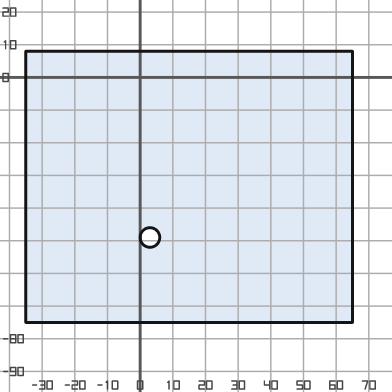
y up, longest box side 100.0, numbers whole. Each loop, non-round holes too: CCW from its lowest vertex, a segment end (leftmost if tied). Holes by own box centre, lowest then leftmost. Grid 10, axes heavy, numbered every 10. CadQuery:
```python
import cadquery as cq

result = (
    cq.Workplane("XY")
    .moveTo(-35.0, -75.0)
    .lineTo(65.0, -75.0)
    .lineTo(65.0, 8.0)
    .lineTo(-35.0, 8.0)
    .close()
    .moveTo(3.0, -49.0)
    .circle(3.0)
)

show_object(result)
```